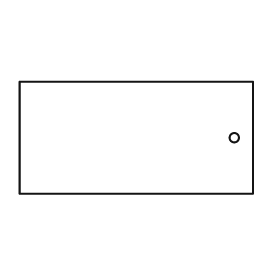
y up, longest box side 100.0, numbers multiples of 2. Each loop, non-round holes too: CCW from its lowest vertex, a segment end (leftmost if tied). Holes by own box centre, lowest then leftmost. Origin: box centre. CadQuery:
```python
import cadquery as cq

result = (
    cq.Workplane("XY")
    .moveTo(-50.0, -24.0)
    .lineTo(50.0, -24.0)
    .lineTo(50.0, 24.0)
    .lineTo(-50.0, 24.0)
    .close()
    .moveTo(42.0, 0.0)
    .circle(2.0)
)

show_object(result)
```